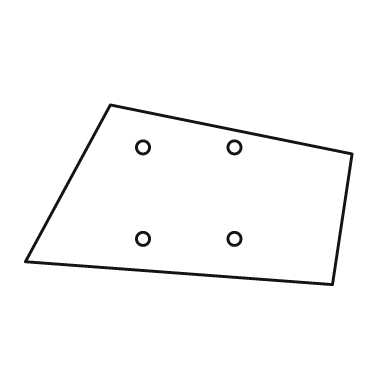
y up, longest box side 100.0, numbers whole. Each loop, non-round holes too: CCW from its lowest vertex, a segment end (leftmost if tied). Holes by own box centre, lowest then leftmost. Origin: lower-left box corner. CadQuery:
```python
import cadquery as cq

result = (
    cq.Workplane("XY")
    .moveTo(94.0, 0.0)
    .lineTo(100.0, 40.0)
    .lineTo(26.0, 55.0)
    .lineTo(0.0, 7.0)
    .close()
    .moveTo(36.0, 14.0)
    .circle(2.0)
    .moveTo(64.0, 14.0)
    .circle(2.0)
    .moveTo(36.0, 42.0)
    .circle(2.0)
    .moveTo(64.0, 42.0)
    .circle(2.0)
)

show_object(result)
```